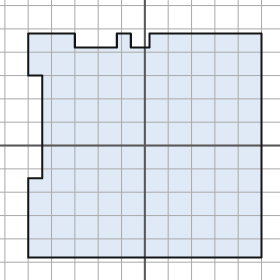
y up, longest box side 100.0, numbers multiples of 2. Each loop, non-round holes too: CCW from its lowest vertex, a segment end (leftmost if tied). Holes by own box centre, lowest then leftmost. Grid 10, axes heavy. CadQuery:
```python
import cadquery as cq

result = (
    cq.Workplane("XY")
    .moveTo(-50.0, -48.0)
    .lineTo(50.0, -48.0)
    .lineTo(50.0, 48.0)
    .lineTo(2.0, 48.0)
    .lineTo(2.0, 42.0)
    .lineTo(-6.0, 42.0)
    .lineTo(-6.0, 48.0)
    .lineTo(-12.0, 48.0)
    .lineTo(-12.0, 42.0)
    .lineTo(-30.0, 42.0)
    .lineTo(-30.0, 48.0)
    .lineTo(-50.0, 48.0)
    .lineTo(-50.0, 30.0)
    .lineTo(-44.0, 30.0)
    .lineTo(-44.0, -14.0)
    .lineTo(-50.0, -14.0)
    .close()
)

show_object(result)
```